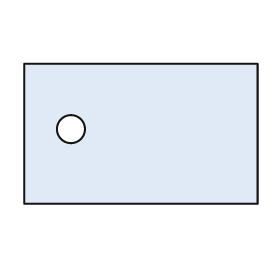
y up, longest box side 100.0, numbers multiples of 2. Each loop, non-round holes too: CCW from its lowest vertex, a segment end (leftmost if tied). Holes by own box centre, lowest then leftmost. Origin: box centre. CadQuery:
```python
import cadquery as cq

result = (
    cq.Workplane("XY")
    .moveTo(-50.0, -30.0)
    .lineTo(50.0, -30.0)
    .lineTo(50.0, 30.0)
    .lineTo(-50.0, 30.0)
    .close()
    .moveTo(-30.0, 2.0)
    .circle(6.0)
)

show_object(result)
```